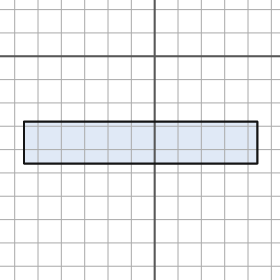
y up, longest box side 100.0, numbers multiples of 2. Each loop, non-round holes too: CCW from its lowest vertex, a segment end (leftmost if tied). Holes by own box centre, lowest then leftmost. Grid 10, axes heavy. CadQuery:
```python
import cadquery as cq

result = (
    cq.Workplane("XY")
    .moveTo(-56.0, -46.0)
    .lineTo(44.0, -46.0)
    .lineTo(44.0, -28.0)
    .lineTo(-56.0, -28.0)
    .close()
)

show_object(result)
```